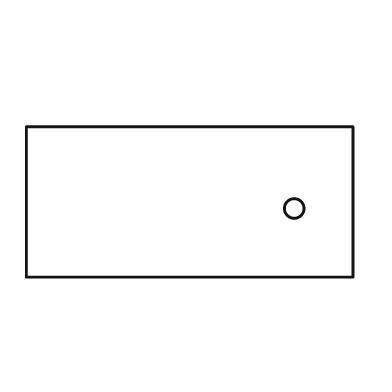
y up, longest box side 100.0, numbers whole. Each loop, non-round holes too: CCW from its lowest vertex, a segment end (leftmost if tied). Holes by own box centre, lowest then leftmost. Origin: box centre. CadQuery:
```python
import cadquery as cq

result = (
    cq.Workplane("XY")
    .moveTo(-50.0, -23.0)
    .lineTo(50.0, -23.0)
    .lineTo(50.0, 23.0)
    .lineTo(-50.0, 23.0)
    .close()
    .moveTo(32.0, -2.0)
    .circle(3.0)
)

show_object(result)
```